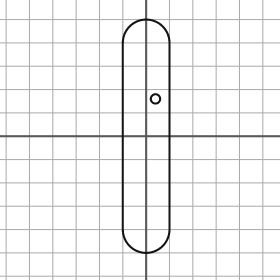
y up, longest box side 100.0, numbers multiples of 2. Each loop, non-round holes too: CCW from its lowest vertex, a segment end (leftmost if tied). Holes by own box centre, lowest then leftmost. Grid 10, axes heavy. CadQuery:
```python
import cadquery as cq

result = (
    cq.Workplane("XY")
    .moveTo(-10.0, -40.0)
    .threePointArc((0.0, -50.0), (10.0, -40.0))
    .lineTo(10.0, 40.0)
    .threePointArc((0.0, 50.0), (-10.0, 40.0))
    .close()
    .moveTo(4.0, 16.0)
    .circle(2.0)
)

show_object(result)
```